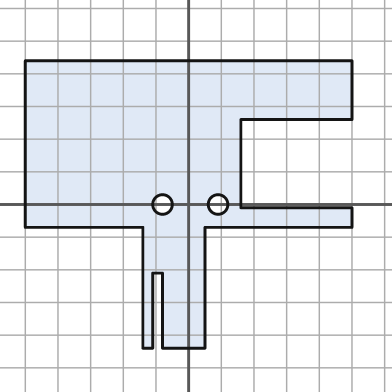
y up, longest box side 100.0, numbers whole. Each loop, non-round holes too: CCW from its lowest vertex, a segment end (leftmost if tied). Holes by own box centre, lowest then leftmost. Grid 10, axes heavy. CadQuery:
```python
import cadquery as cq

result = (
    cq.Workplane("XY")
    .moveTo(-14.0, -44.0)
    .lineTo(-11.0, -44.0)
    .lineTo(-11.0, -21.0)
    .lineTo(-8.0, -21.0)
    .lineTo(-8.0, -44.0)
    .lineTo(5.0, -44.0)
    .lineTo(5.0, -7.0)
    .lineTo(50.0, -7.0)
    .lineTo(50.0, -1.0)
    .lineTo(16.0, -1.0)
    .lineTo(16.0, 26.0)
    .lineTo(50.0, 26.0)
    .lineTo(50.0, 44.0)
    .lineTo(-50.0, 44.0)
    .lineTo(-50.0, -7.0)
    .lineTo(-14.0, -7.0)
    .close()
    .moveTo(-8.0, 0.0)
    .circle(3.0)
    .moveTo(9.0, 0.0)
    .circle(3.0)
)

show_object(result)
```